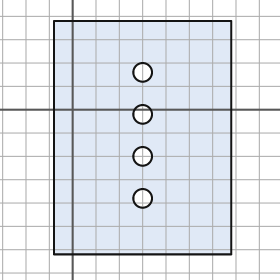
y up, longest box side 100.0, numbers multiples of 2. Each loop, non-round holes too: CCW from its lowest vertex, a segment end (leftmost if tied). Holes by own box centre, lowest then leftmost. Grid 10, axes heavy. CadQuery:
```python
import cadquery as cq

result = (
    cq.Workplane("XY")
    .moveTo(-8.0, -62.0)
    .lineTo(68.0, -62.0)
    .lineTo(68.0, 38.0)
    .lineTo(-8.0, 38.0)
    .close()
    .moveTo(30.0, -38.0)
    .circle(4.0)
    .moveTo(30.0, -20.0)
    .circle(4.0)
    .moveTo(30.0, -2.0)
    .circle(4.0)
    .moveTo(30.0, 16.0)
    .circle(4.0)
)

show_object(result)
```